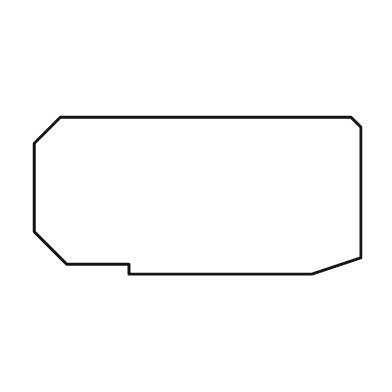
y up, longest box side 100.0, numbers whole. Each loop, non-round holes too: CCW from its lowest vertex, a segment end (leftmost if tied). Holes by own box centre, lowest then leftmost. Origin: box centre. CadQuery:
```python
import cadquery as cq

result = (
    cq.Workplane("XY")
    .moveTo(-21.0, -24.0)
    .lineTo(35.0, -24.0)
    .lineTo(50.0, -19.0)
    .lineTo(50.0, 21.0)
    .lineTo(47.0, 24.0)
    .lineTo(-42.0, 24.0)
    .lineTo(-50.0, 16.0)
    .lineTo(-50.0, -11.0)
    .lineTo(-40.0, -21.0)
    .lineTo(-21.0, -21.0)
    .close()
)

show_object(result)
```